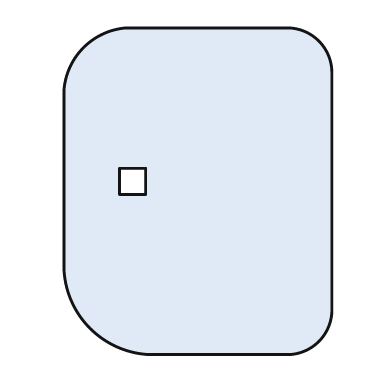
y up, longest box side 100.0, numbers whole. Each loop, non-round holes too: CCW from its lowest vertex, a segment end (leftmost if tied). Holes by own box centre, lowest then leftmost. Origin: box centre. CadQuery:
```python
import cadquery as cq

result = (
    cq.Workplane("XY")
    .moveTo(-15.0, -50.0)
    .lineTo(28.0, -50.0)
    .threePointArc((37.0, -46.0), (41.0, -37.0))
    .lineTo(41.0, 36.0)
    .threePointArc((37.0, 46.0), (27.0, 50.0))
    .lineTo(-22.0, 50.0)
    .threePointArc((-35.0, 44.0), (-41.0, 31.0))
    .lineTo(-41.0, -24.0)
    .threePointArc((-33.0, -42.0), (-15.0, -50.0))
    .close()
    .moveTo(-24.0, -1.0)
    .lineTo(-16.0, -1.0)
    .lineTo(-16.0, 7.0)
    .lineTo(-24.0, 7.0)
    .close()
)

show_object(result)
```